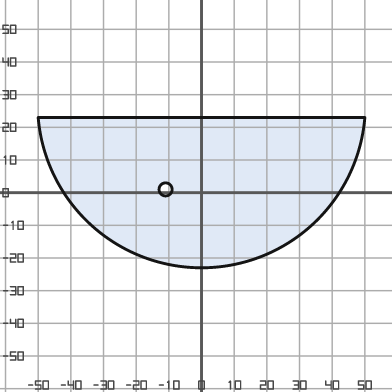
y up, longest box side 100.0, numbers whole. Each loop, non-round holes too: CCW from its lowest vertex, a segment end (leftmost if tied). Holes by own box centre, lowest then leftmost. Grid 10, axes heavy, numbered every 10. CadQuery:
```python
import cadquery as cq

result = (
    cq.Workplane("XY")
    .moveTo(-50.0, 23.0)
    .threePointArc((0.0, -23.0), (50.0, 23.0))
    .close()
    .moveTo(-11.0, 1.0)
    .circle(2.0)
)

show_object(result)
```